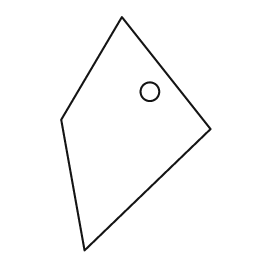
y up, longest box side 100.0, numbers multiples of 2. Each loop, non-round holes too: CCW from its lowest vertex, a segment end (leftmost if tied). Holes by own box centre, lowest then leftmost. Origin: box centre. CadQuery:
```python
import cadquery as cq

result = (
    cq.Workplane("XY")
    .moveTo(-22.0, -50.0)
    .lineTo(32.0, 2.0)
    .lineTo(-6.0, 50.0)
    .lineTo(-32.0, 6.0)
    .close()
    .moveTo(6.0, 18.0)
    .circle(4.0)
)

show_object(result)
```